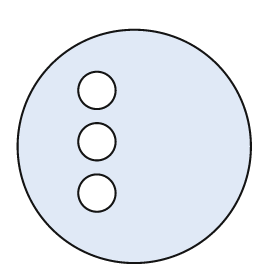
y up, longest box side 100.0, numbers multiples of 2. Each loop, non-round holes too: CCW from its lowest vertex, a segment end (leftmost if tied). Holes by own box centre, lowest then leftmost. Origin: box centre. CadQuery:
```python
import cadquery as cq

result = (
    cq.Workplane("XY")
    .moveTo(0.0, 0.0)
    .circle(50.0)
    .moveTo(-16.0, -20.0)
    .circle(8.0)
    .moveTo(-16.0, 2.0)
    .circle(8.0)
    .moveTo(-16.0, 24.0)
    .circle(8.0)
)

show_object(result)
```